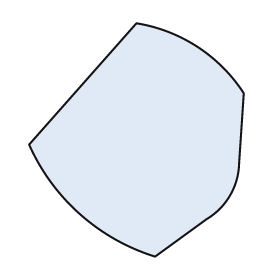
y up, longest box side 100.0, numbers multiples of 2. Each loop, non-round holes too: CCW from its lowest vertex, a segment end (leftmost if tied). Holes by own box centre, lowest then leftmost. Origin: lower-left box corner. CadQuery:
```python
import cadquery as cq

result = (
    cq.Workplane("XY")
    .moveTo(54.0, 0.0)
    .lineTo(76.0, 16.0)
    .threePointArc((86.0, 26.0), (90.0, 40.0))
    .lineTo(92.0, 70.0)
    .threePointArc((72.0, 90.0), (46.0, 100.0))
    .lineTo(0.0, 48.0)
    .threePointArc((22.0, 18.0), (54.0, 0.0))
    .close()
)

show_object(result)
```